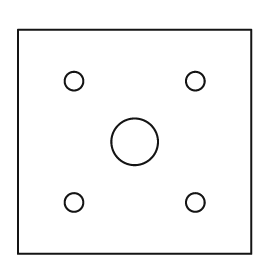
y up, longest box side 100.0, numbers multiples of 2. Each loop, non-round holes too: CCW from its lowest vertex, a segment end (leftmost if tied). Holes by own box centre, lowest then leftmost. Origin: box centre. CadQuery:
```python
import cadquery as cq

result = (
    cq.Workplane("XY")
    .moveTo(-50.0, -48.0)
    .lineTo(50.0, -48.0)
    .lineTo(50.0, 48.0)
    .lineTo(-50.0, 48.0)
    .close()
    .moveTo(-26.0, -26.0)
    .circle(4.0)
    .moveTo(26.0, -26.0)
    .circle(4.0)
    .moveTo(0.0, 0.0)
    .circle(10.0)
    .moveTo(-26.0, 26.0)
    .circle(4.0)
    .moveTo(26.0, 26.0)
    .circle(4.0)
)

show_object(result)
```